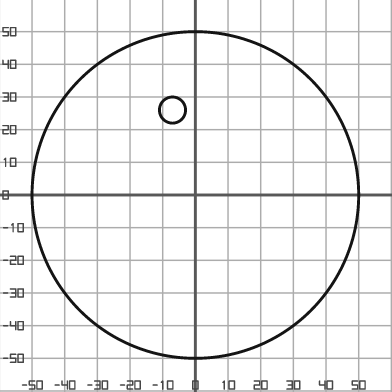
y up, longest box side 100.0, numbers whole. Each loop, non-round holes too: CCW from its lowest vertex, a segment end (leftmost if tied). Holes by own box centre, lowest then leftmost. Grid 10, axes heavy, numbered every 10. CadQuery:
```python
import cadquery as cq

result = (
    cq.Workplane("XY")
    .moveTo(0.0, 0.0)
    .circle(50.0)
    .moveTo(-7.0, 26.0)
    .circle(4.0)
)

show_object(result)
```